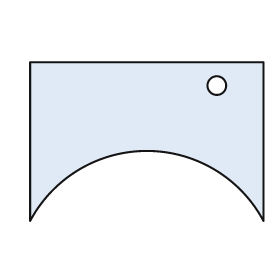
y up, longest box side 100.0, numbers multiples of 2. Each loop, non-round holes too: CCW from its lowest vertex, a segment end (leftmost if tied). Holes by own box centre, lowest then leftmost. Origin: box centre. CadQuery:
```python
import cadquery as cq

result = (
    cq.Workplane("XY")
    .moveTo(-50.0, -34.0)
    .threePointArc((0.0, -4.0), (50.0, -34.0))
    .lineTo(50.0, 34.0)
    .lineTo(-50.0, 34.0)
    .close()
    .moveTo(30.0, 24.0)
    .circle(4.0)
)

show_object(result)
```